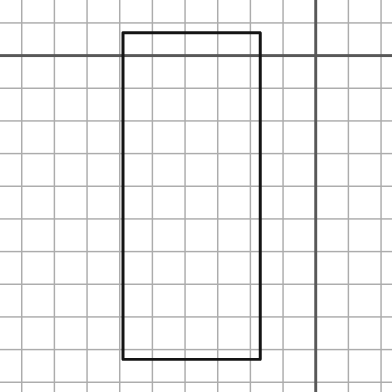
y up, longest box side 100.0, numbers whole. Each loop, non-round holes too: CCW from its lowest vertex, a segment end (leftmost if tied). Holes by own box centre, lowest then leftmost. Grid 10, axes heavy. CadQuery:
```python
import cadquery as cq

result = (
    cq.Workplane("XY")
    .moveTo(-59.0, -93.0)
    .lineTo(-17.0, -93.0)
    .lineTo(-17.0, 7.0)
    .lineTo(-59.0, 7.0)
    .close()
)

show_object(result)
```